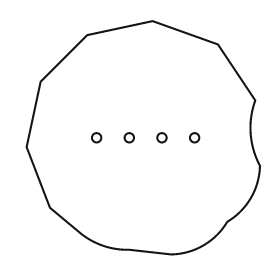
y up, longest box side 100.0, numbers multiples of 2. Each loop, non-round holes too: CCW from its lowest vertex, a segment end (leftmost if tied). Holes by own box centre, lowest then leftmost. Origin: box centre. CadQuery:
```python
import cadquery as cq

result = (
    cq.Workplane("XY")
    .moveTo(12.0, -50.0)
    .threePointArc((26.0, -46.0), (36.0, -36.0))
    .threePointArc((46.0, -26.0), (50.0, -12.0))
    .threePointArc((46.0, 2.0), (48.0, 16.0))
    .lineTo(32.0, 40.0)
    .lineTo(4.0, 50.0)
    .lineTo(-24.0, 44.0)
    .lineTo(-44.0, 24.0)
    .lineTo(-50.0, -4.0)
    .lineTo(-40.0, -30.0)
    .lineTo(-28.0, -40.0)
    .threePointArc((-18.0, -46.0), (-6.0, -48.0))
    .close()
    .moveTo(-20.0, 0.0)
    .circle(2.0)
    .moveTo(-6.0, 0.0)
    .circle(2.0)
    .moveTo(8.0, 0.0)
    .circle(2.0)
    .moveTo(22.0, 0.0)
    .circle(2.0)
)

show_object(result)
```